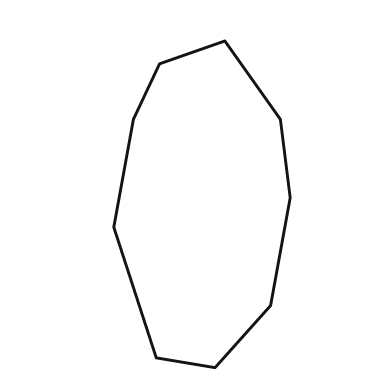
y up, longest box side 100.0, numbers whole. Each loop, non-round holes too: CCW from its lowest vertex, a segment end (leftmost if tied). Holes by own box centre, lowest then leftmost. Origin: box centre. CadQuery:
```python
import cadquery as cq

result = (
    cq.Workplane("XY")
    .moveTo(4.0, -50.0)
    .lineTo(21.0, -31.0)
    .lineTo(27.0, 2.0)
    .lineTo(24.0, 26.0)
    .lineTo(7.0, 50.0)
    .lineTo(-13.0, 43.0)
    .lineTo(-21.0, 26.0)
    .lineTo(-27.0, -7.0)
    .lineTo(-14.0, -47.0)
    .close()
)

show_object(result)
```